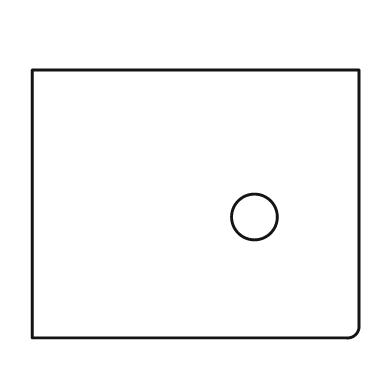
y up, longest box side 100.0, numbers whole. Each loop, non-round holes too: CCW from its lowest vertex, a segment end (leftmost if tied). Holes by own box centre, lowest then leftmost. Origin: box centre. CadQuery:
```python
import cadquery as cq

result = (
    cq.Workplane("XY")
    .moveTo(-50.0, -41.0)
    .lineTo(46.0, -41.0)
    .threePointArc((49.0, -40.0), (50.0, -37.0))
    .lineTo(50.0, 41.0)
    .lineTo(-50.0, 41.0)
    .close()
    .moveTo(18.0, -4.0)
    .circle(7.0)
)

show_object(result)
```